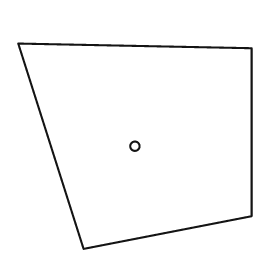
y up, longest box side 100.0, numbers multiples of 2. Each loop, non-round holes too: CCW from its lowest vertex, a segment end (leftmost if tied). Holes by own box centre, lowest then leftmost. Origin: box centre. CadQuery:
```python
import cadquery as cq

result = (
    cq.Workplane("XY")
    .moveTo(-22.0, -44.0)
    .lineTo(50.0, -30.0)
    .lineTo(50.0, 42.0)
    .lineTo(-50.0, 44.0)
    .close()
    .moveTo(0.0, 0.0)
    .circle(2.0)
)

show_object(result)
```